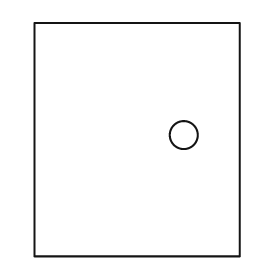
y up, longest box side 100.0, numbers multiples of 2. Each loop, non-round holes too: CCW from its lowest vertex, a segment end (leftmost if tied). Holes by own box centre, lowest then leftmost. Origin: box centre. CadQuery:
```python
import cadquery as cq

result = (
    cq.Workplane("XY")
    .moveTo(-44.0, -50.0)
    .lineTo(44.0, -50.0)
    .lineTo(44.0, 50.0)
    .lineTo(-44.0, 50.0)
    .close()
    .moveTo(20.0, 2.0)
    .circle(6.0)
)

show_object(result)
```